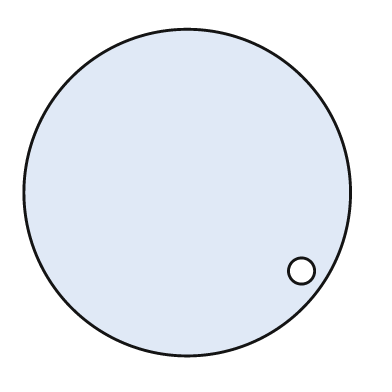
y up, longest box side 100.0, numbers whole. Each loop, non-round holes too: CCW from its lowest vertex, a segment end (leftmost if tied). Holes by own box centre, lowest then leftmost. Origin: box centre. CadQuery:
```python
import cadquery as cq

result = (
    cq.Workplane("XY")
    .moveTo(0.0, 0.0)
    .circle(50.0)
    .moveTo(35.0, -24.0)
    .circle(4.0)
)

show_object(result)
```